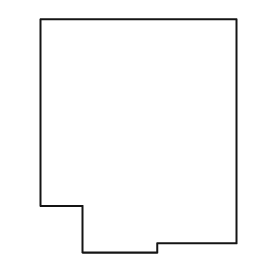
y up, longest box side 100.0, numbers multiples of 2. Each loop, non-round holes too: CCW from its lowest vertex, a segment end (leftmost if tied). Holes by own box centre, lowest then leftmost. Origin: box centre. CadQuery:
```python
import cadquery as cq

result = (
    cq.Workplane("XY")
    .moveTo(-24.0, -50.0)
    .lineTo(8.0, -50.0)
    .lineTo(8.0, -46.0)
    .lineTo(42.0, -46.0)
    .lineTo(42.0, 50.0)
    .lineTo(-42.0, 50.0)
    .lineTo(-42.0, -30.0)
    .lineTo(-24.0, -30.0)
    .close()
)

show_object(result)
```